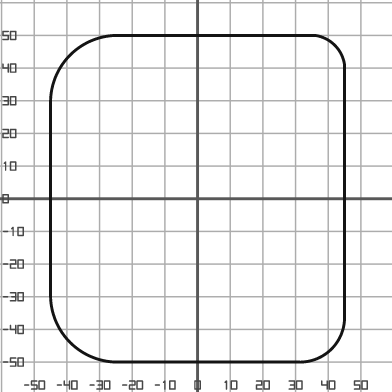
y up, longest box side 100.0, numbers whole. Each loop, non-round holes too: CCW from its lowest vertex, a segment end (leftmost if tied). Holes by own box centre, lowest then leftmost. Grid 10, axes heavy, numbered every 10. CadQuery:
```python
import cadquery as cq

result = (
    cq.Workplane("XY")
    .moveTo(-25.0, -50.0)
    .lineTo(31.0, -50.0)
    .threePointArc((41.0, -46.0), (45.0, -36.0))
    .lineTo(45.0, 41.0)
    .threePointArc((42.0, 47.0), (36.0, 50.0))
    .lineTo(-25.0, 50.0)
    .threePointArc((-39.0, 44.0), (-45.0, 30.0))
    .lineTo(-45.0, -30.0)
    .threePointArc((-39.0, -44.0), (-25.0, -50.0))
    .close()
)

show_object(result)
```